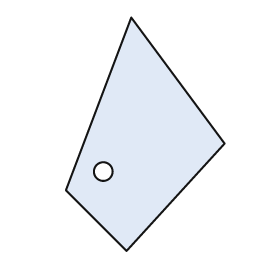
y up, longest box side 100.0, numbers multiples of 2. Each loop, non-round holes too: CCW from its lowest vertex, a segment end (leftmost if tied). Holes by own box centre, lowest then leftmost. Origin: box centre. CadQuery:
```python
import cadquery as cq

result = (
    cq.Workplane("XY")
    .moveTo(-8.0, -50.0)
    .lineTo(34.0, -4.0)
    .lineTo(-6.0, 50.0)
    .lineTo(-34.0, -24.0)
    .close()
    .moveTo(-18.0, -16.0)
    .circle(4.0)
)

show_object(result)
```